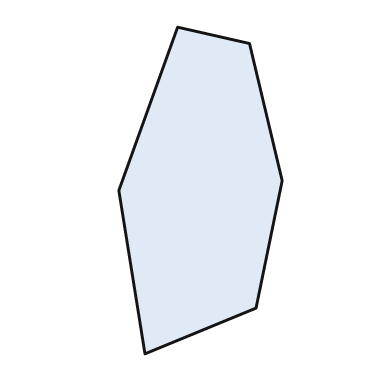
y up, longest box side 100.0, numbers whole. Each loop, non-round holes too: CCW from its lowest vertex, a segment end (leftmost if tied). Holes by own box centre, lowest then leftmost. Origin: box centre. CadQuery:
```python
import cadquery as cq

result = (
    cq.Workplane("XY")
    .moveTo(-17.0, -50.0)
    .lineTo(17.0, -36.0)
    .lineTo(25.0, 3.0)
    .lineTo(15.0, 45.0)
    .lineTo(-7.0, 50.0)
    .lineTo(-25.0, 0.0)
    .close()
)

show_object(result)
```